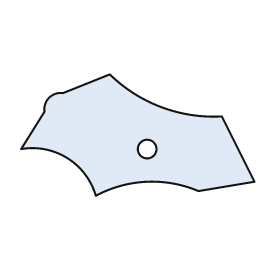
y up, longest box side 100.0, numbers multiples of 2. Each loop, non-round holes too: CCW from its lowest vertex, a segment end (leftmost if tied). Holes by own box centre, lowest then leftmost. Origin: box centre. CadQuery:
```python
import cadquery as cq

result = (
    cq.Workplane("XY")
    .moveTo(-18.0, -26.0)
    .threePointArc((4.0, -20.0), (26.0, -24.0))
    .lineTo(50.0, -20.0)
    .lineTo(36.0, 8.0)
    .threePointArc((10.0, 12.0), (-12.0, 26.0))
    .lineTo(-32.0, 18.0)
    .threePointArc((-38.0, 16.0), (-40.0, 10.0))
    .lineTo(-50.0, -6.0)
    .threePointArc((-30.0, -10.0), (-18.0, -26.0))
    .close()
    .moveTo(4.0, -6.0)
    .circle(4.0)
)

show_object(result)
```